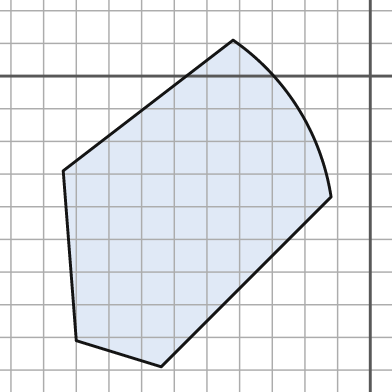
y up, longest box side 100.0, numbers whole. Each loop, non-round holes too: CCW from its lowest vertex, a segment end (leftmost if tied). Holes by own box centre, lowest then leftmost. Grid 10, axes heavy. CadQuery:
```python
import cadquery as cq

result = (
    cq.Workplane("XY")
    .moveTo(-64.0, -89.0)
    .lineTo(-12.0, -37.0)
    .threePointArc((-22.0, -10.0), (-42.0, 11.0))
    .lineTo(-94.0, -29.0)
    .lineTo(-90.0, -81.0)
    .close()
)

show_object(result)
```